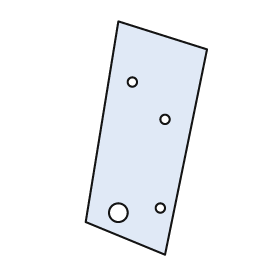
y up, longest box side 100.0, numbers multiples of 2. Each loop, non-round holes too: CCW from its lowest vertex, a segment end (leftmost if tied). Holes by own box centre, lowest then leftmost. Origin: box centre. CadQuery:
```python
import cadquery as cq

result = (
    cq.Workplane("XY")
    .moveTo(8.0, -50.0)
    .lineTo(26.0, 38.0)
    .lineTo(-12.0, 50.0)
    .lineTo(-26.0, -36.0)
    .close()
    .moveTo(-12.0, -32.0)
    .circle(4.0)
    .moveTo(6.0, -30.0)
    .circle(2.0)
    .moveTo(8.0, 8.0)
    .circle(2.0)
    .moveTo(-6.0, 24.0)
    .circle(2.0)
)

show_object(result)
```